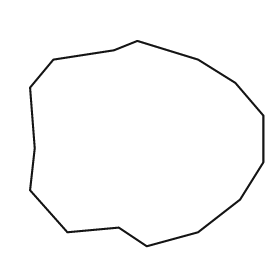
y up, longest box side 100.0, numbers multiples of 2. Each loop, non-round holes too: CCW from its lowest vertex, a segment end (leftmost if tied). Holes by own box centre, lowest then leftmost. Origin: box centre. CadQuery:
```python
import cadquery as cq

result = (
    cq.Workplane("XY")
    .moveTo(0.0, -44.0)
    .lineTo(22.0, -38.0)
    .lineTo(40.0, -24.0)
    .lineTo(50.0, -8.0)
    .lineTo(50.0, 12.0)
    .lineTo(38.0, 26.0)
    .lineTo(22.0, 36.0)
    .lineTo(-4.0, 44.0)
    .lineTo(-14.0, 40.0)
    .lineTo(-40.0, 36.0)
    .lineTo(-50.0, 24.0)
    .lineTo(-48.0, -2.0)
    .lineTo(-50.0, -20.0)
    .lineTo(-34.0, -38.0)
    .lineTo(-12.0, -36.0)
    .close()
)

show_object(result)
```